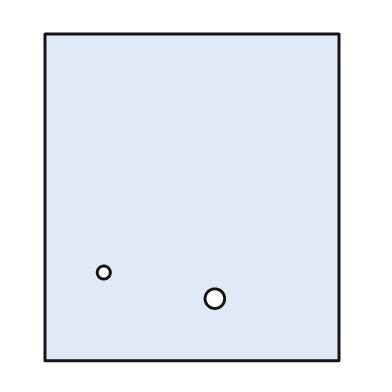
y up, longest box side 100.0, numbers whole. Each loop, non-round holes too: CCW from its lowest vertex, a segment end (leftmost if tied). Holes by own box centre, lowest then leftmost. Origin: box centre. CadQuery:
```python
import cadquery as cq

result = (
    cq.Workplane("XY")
    .moveTo(-45.0, -50.0)
    .lineTo(45.0, -50.0)
    .lineTo(45.0, 50.0)
    .lineTo(-45.0, 50.0)
    .close()
    .moveTo(7.0, -31.0)
    .circle(3.0)
    .moveTo(-27.0, -23.0)
    .circle(2.0)
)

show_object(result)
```